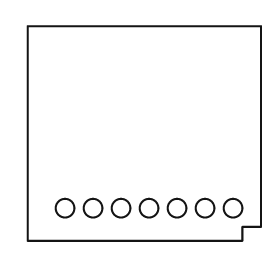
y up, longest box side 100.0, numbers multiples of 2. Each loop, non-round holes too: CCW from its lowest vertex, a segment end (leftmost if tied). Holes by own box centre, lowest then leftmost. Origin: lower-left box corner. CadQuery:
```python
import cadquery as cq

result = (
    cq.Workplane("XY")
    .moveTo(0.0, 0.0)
    .lineTo(92.0, 0.0)
    .lineTo(92.0, 6.0)
    .lineTo(100.0, 6.0)
    .lineTo(100.0, 92.0)
    .lineTo(0.0, 92.0)
    .close()
    .moveTo(16.0, 14.0)
    .circle(4.0)
    .moveTo(28.0, 14.0)
    .circle(4.0)
    .moveTo(40.0, 14.0)
    .circle(4.0)
    .moveTo(52.0, 14.0)
    .circle(4.0)
    .moveTo(64.0, 14.0)
    .circle(4.0)
    .moveTo(76.0, 14.0)
    .circle(4.0)
    .moveTo(88.0, 14.0)
    .circle(4.0)
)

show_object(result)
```